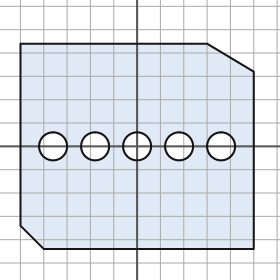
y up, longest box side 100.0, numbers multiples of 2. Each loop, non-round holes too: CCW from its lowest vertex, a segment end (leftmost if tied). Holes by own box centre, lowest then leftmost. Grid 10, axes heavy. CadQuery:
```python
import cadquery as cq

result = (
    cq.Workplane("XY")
    .moveTo(-40.0, -44.0)
    .lineTo(50.0, -44.0)
    .lineTo(50.0, 32.0)
    .lineTo(30.0, 44.0)
    .lineTo(-50.0, 44.0)
    .lineTo(-50.0, -34.0)
    .close()
    .moveTo(-36.0, 0.0)
    .circle(6.0)
    .moveTo(-18.0, 0.0)
    .circle(6.0)
    .moveTo(0.0, 0.0)
    .circle(6.0)
    .moveTo(18.0, 0.0)
    .circle(6.0)
    .moveTo(36.0, 0.0)
    .circle(6.0)
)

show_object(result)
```